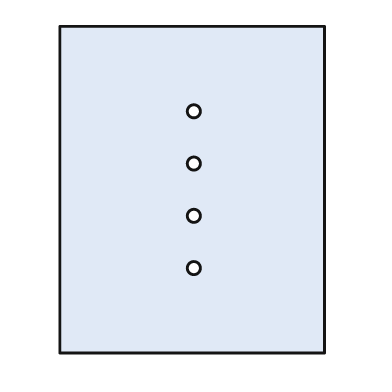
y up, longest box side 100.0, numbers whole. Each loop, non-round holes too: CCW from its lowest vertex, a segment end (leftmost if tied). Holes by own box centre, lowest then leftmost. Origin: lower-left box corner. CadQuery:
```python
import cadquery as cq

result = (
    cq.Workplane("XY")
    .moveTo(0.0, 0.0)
    .lineTo(81.0, 0.0)
    .lineTo(81.0, 100.0)
    .lineTo(0.0, 100.0)
    .close()
    .moveTo(41.0, 26.0)
    .circle(2.0)
    .moveTo(41.0, 42.0)
    .circle(2.0)
    .moveTo(41.0, 58.0)
    .circle(2.0)
    .moveTo(41.0, 74.0)
    .circle(2.0)
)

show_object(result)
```